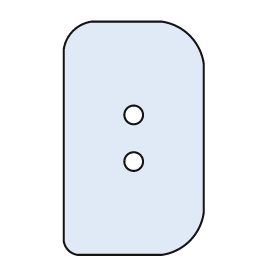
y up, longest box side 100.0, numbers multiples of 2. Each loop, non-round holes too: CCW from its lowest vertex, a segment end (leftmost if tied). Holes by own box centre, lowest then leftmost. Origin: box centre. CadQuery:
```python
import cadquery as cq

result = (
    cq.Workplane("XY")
    .moveTo(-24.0, -50.0)
    .lineTo(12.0, -50.0)
    .threePointArc((24.0, -44.0), (30.0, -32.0))
    .lineTo(30.0, 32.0)
    .threePointArc((24.0, 44.0), (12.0, 50.0))
    .lineTo(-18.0, 50.0)
    .threePointArc((-26.0, 46.0), (-30.0, 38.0))
    .lineTo(-30.0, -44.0)
    .threePointArc((-28.0, -48.0), (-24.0, -50.0))
    .close()
    .moveTo(0.0, -10.0)
    .circle(4.0)
    .moveTo(0.0, 10.0)
    .circle(4.0)
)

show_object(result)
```